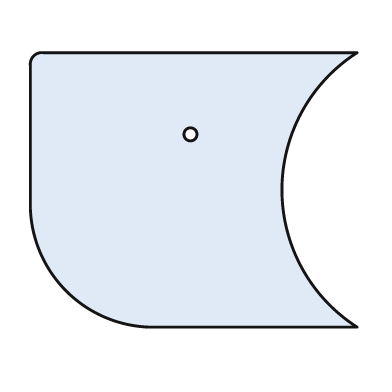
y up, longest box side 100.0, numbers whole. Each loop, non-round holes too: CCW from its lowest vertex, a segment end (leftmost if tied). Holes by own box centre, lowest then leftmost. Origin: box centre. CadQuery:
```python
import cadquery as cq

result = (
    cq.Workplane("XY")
    .moveTo(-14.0, -42.0)
    .lineTo(50.0, -42.0)
    .threePointArc((27.0, 0.0), (50.0, 42.0))
    .lineTo(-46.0, 42.0)
    .threePointArc((-49.0, 41.0), (-50.0, 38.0))
    .lineTo(-50.0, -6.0)
    .threePointArc((-39.0, -31.0), (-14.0, -42.0))
    .close()
    .moveTo(-1.0, 17.0)
    .circle(2.0)
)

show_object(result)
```